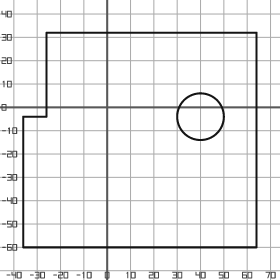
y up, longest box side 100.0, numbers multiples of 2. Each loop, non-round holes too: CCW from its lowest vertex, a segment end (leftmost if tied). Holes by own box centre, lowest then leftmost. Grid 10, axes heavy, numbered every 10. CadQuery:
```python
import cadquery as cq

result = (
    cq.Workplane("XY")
    .moveTo(-36.0, -60.0)
    .lineTo(64.0, -60.0)
    .lineTo(64.0, 32.0)
    .lineTo(-26.0, 32.0)
    .lineTo(-26.0, -4.0)
    .lineTo(-36.0, -4.0)
    .close()
    .moveTo(40.0, -4.0)
    .circle(10.0)
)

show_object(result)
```